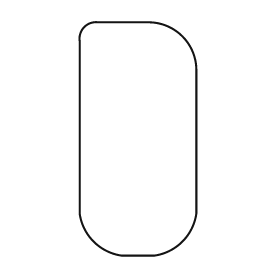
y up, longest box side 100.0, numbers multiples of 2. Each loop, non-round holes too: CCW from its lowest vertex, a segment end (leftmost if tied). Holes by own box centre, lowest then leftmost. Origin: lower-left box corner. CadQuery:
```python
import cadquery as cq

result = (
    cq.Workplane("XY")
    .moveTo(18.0, 0.0)
    .lineTo(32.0, 0.0)
    .threePointArc((44.0, 6.0), (50.0, 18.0))
    .lineTo(50.0, 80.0)
    .threePointArc((44.0, 94.0), (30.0, 100.0))
    .lineTo(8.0, 100.0)
    .threePointArc((2.0, 98.0), (0.0, 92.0))
    .lineTo(0.0, 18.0)
    .threePointArc((6.0, 6.0), (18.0, 0.0))
    .close()
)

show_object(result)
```